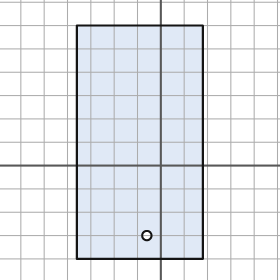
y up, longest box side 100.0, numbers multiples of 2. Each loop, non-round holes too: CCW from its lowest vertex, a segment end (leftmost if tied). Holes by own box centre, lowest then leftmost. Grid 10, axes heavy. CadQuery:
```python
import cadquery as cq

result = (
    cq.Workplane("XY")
    .moveTo(-36.0, -40.0)
    .lineTo(18.0, -40.0)
    .lineTo(18.0, 60.0)
    .lineTo(-36.0, 60.0)
    .close()
    .moveTo(-6.0, -30.0)
    .circle(2.0)
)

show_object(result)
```